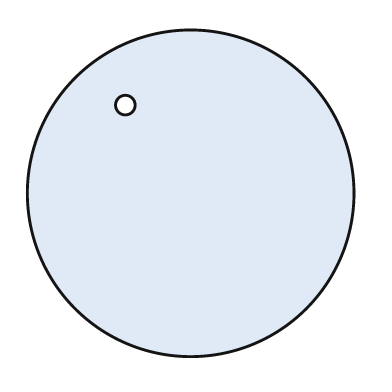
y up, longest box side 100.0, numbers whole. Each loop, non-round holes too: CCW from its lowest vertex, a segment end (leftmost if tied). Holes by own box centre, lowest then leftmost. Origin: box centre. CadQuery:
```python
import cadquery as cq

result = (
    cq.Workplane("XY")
    .moveTo(0.0, 0.0)
    .circle(50.0)
    .moveTo(-20.0, 27.0)
    .circle(3.0)
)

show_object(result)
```